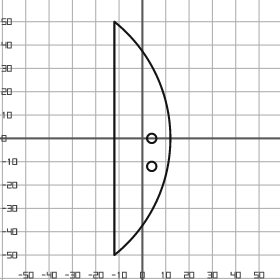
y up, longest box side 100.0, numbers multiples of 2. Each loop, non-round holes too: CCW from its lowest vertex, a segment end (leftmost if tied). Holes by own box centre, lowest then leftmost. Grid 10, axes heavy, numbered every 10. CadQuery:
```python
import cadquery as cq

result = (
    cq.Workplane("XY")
    .moveTo(-12.0, -50.0)
    .threePointArc((12.0, 0.0), (-12.0, 50.0))
    .close()
    .moveTo(4.0, -12.0)
    .circle(2.0)
    .moveTo(4.0, 0.0)
    .circle(2.0)
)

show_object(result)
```